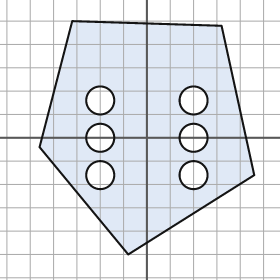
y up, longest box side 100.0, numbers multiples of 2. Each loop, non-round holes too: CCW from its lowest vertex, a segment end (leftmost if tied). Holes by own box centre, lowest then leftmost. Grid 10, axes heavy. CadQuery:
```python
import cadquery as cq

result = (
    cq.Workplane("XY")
    .moveTo(-8.0, -50.0)
    .lineTo(46.0, -16.0)
    .lineTo(32.0, 48.0)
    .lineTo(-32.0, 50.0)
    .lineTo(-46.0, -4.0)
    .close()
    .moveTo(-20.0, -16.0)
    .circle(6.0)
    .moveTo(20.0, -16.0)
    .circle(6.0)
    .moveTo(-20.0, 0.0)
    .circle(6.0)
    .moveTo(20.0, 0.0)
    .circle(6.0)
    .moveTo(-20.0, 16.0)
    .circle(6.0)
    .moveTo(20.0, 16.0)
    .circle(6.0)
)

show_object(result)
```